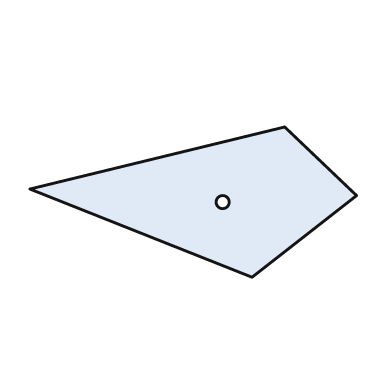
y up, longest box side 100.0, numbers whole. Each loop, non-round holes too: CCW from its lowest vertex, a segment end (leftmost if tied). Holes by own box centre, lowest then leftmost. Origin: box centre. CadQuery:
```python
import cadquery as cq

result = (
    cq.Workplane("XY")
    .moveTo(18.0, -23.0)
    .lineTo(50.0, 2.0)
    .lineTo(28.0, 23.0)
    .lineTo(-50.0, 4.0)
    .close()
    .moveTo(9.0, 0.0)
    .circle(2.0)
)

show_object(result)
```